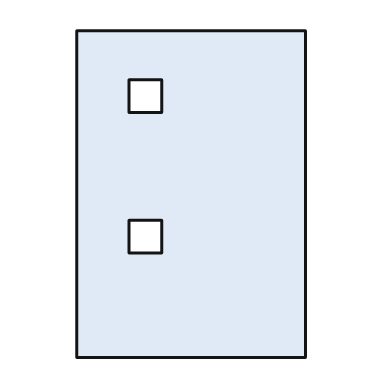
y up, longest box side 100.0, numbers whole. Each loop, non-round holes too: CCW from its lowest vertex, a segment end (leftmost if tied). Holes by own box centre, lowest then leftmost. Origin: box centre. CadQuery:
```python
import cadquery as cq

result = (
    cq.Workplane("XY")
    .moveTo(-35.0, -50.0)
    .lineTo(35.0, -50.0)
    .lineTo(35.0, 50.0)
    .lineTo(-35.0, 50.0)
    .close()
    .moveTo(-19.0, -18.0)
    .lineTo(-9.0, -18.0)
    .lineTo(-9.0, -8.0)
    .lineTo(-19.0, -8.0)
    .close()
    .moveTo(-19.0, 25.0)
    .lineTo(-9.0, 25.0)
    .lineTo(-9.0, 35.0)
    .lineTo(-19.0, 35.0)
    .close()
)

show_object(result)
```